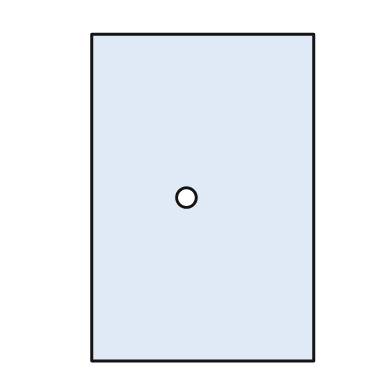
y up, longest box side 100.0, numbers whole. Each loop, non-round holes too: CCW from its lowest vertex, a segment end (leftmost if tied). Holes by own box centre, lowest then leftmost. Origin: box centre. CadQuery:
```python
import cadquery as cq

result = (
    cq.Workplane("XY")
    .moveTo(-34.0, -50.0)
    .lineTo(34.0, -50.0)
    .lineTo(34.0, 50.0)
    .lineTo(-34.0, 50.0)
    .close()
    .moveTo(-5.0, 0.0)
    .circle(3.0)
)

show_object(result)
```